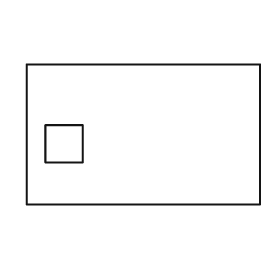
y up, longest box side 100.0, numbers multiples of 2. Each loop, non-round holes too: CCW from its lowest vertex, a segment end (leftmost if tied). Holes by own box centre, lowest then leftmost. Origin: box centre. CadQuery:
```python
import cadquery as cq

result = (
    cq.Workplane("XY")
    .moveTo(-50.0, -30.0)
    .lineTo(50.0, -30.0)
    .lineTo(50.0, 30.0)
    .lineTo(-50.0, 30.0)
    .close()
    .moveTo(-42.0, -12.0)
    .lineTo(-26.0, -12.0)
    .lineTo(-26.0, 4.0)
    .lineTo(-42.0, 4.0)
    .close()
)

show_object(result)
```